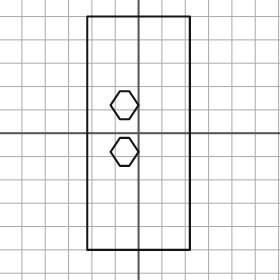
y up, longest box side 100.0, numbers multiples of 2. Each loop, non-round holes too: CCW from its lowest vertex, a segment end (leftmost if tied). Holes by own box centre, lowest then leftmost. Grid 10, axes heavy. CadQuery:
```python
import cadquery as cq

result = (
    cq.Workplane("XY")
    .moveTo(-22.0, -50.0)
    .lineTo(22.0, -50.0)
    .lineTo(22.0, 50.0)
    .lineTo(-22.0, 50.0)
    .close()
    .moveTo(-8.0, -14.0)
    .lineTo(-4.0, -14.0)
    .lineTo(0.0, -8.0)
    .lineTo(-4.0, -2.0)
    .lineTo(-8.0, -2.0)
    .lineTo(-12.0, -8.0)
    .close()
    .moveTo(-8.0, 6.0)
    .lineTo(-4.0, 6.0)
    .lineTo(0.0, 12.0)
    .lineTo(-4.0, 18.0)
    .lineTo(-8.0, 18.0)
    .lineTo(-12.0, 12.0)
    .close()
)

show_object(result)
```